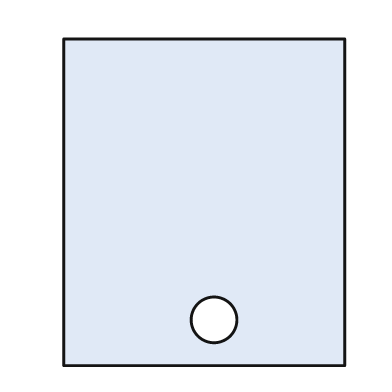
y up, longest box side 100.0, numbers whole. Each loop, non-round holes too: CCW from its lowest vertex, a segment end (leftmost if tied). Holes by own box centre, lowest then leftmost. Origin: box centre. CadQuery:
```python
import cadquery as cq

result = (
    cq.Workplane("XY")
    .moveTo(-43.0, -50.0)
    .lineTo(43.0, -50.0)
    .lineTo(43.0, 50.0)
    .lineTo(-43.0, 50.0)
    .close()
    .moveTo(3.0, -36.0)
    .circle(7.0)
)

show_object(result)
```